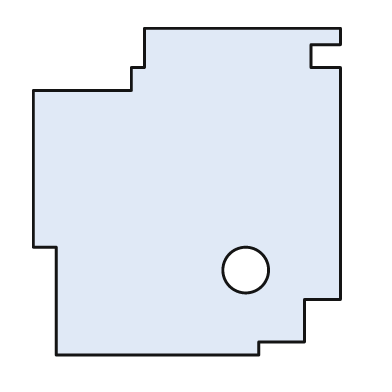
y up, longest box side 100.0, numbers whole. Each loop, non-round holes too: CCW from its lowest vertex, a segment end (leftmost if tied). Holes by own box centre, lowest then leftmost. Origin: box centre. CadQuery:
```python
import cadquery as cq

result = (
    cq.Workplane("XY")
    .moveTo(-40.0, -50.0)
    .lineTo(22.0, -50.0)
    .lineTo(22.0, -46.0)
    .lineTo(36.0, -46.0)
    .lineTo(36.0, -33.0)
    .lineTo(47.0, -33.0)
    .lineTo(47.0, 38.0)
    .lineTo(38.0, 38.0)
    .lineTo(38.0, 45.0)
    .lineTo(47.0, 45.0)
    .lineTo(47.0, 50.0)
    .lineTo(-13.0, 50.0)
    .lineTo(-13.0, 38.0)
    .lineTo(-17.0, 38.0)
    .lineTo(-17.0, 31.0)
    .lineTo(-47.0, 31.0)
    .lineTo(-47.0, -17.0)
    .lineTo(-40.0, -17.0)
    .close()
    .moveTo(18.0, -24.0)
    .circle(7.0)
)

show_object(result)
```